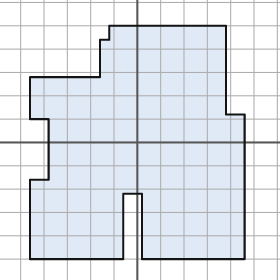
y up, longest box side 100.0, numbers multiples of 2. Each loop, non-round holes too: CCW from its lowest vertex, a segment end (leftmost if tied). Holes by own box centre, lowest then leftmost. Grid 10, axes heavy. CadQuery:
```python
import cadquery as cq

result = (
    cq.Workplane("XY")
    .moveTo(-46.0, -50.0)
    .lineTo(-6.0, -50.0)
    .lineTo(-6.0, -22.0)
    .lineTo(2.0, -22.0)
    .lineTo(2.0, -50.0)
    .lineTo(46.0, -50.0)
    .lineTo(46.0, 12.0)
    .lineTo(38.0, 12.0)
    .lineTo(38.0, 50.0)
    .lineTo(-12.0, 50.0)
    .lineTo(-12.0, 44.0)
    .lineTo(-16.0, 44.0)
    .lineTo(-16.0, 28.0)
    .lineTo(-46.0, 28.0)
    .lineTo(-46.0, 10.0)
    .lineTo(-38.0, 10.0)
    .lineTo(-38.0, -16.0)
    .lineTo(-46.0, -16.0)
    .close()
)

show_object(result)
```